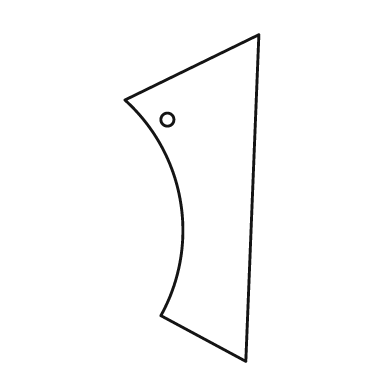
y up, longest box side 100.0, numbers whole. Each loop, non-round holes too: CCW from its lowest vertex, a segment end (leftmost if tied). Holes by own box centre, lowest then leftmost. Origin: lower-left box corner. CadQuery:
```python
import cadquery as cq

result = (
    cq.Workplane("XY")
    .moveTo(37.0, 0.0)
    .lineTo(41.0, 100.0)
    .lineTo(0.0, 80.0)
    .threePointArc((17.0, 49.0), (11.0, 14.0))
    .close()
    .moveTo(13.0, 74.0)
    .circle(2.0)
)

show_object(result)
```